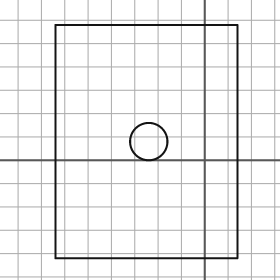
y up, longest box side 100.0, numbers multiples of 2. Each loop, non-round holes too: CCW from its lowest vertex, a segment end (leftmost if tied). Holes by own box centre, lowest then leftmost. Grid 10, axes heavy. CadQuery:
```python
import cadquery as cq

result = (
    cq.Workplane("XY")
    .moveTo(-64.0, -42.0)
    .lineTo(14.0, -42.0)
    .lineTo(14.0, 58.0)
    .lineTo(-64.0, 58.0)
    .close()
    .moveTo(-24.0, 8.0)
    .circle(8.0)
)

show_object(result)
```